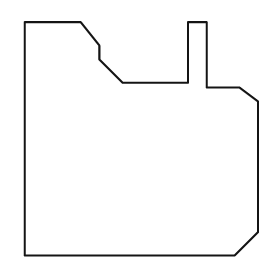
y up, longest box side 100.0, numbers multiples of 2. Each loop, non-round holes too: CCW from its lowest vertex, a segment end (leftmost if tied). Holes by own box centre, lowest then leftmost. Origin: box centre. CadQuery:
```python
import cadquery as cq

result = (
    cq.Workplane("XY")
    .moveTo(-50.0, -50.0)
    .lineTo(40.0, -50.0)
    .lineTo(50.0, -40.0)
    .lineTo(50.0, 16.0)
    .lineTo(42.0, 22.0)
    .lineTo(28.0, 22.0)
    .lineTo(28.0, 50.0)
    .lineTo(20.0, 50.0)
    .lineTo(20.0, 24.0)
    .lineTo(-8.0, 24.0)
    .lineTo(-18.0, 34.0)
    .lineTo(-18.0, 40.0)
    .lineTo(-26.0, 50.0)
    .lineTo(-50.0, 50.0)
    .close()
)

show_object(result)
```